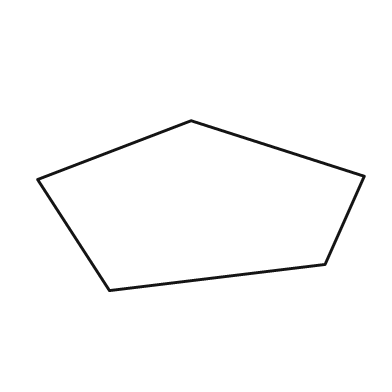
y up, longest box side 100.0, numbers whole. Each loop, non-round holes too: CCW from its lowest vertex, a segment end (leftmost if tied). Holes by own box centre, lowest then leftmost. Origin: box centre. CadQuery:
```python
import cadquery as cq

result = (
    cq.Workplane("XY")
    .moveTo(-28.0, -26.0)
    .lineTo(38.0, -18.0)
    .lineTo(50.0, 9.0)
    .lineTo(-3.0, 26.0)
    .lineTo(-50.0, 8.0)
    .close()
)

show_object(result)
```